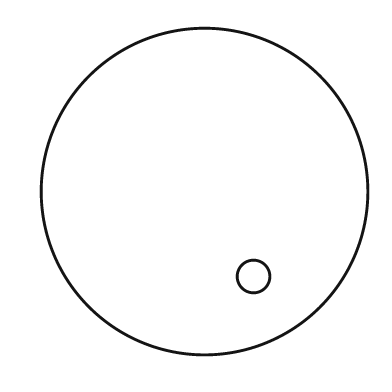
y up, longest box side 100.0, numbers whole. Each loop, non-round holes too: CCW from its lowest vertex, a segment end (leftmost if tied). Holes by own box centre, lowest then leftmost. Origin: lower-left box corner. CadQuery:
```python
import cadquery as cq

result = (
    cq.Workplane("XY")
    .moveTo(50.0, 50.0)
    .circle(50.0)
    .moveTo(65.0, 24.0)
    .circle(5.0)
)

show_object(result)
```